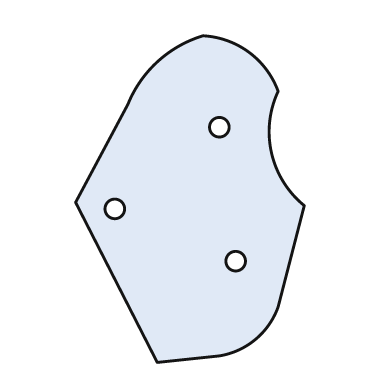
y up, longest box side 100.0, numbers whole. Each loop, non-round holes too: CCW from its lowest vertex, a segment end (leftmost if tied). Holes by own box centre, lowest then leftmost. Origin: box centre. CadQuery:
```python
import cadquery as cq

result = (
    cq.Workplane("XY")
    .moveTo(-10.0, -50.0)
    .lineTo(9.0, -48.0)
    .threePointArc((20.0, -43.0), (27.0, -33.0))
    .lineTo(35.0, -2.0)
    .threePointArc((25.0, 14.0), (27.0, 33.0))
    .threePointArc((18.0, 45.0), (4.0, 50.0))
    .threePointArc((-10.0, 42.0), (-19.0, 29.0))
    .lineTo(-35.0, -1.0)
    .close()
    .moveTo(14.0, -19.0)
    .circle(3.0)
    .moveTo(-23.0, -3.0)
    .circle(3.0)
    .moveTo(9.0, 22.0)
    .circle(3.0)
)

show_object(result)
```